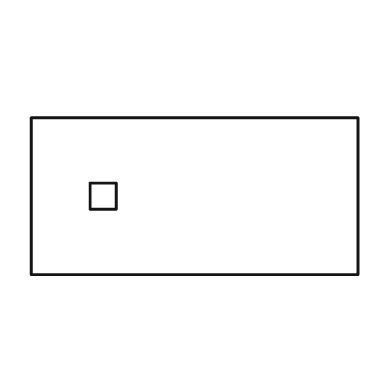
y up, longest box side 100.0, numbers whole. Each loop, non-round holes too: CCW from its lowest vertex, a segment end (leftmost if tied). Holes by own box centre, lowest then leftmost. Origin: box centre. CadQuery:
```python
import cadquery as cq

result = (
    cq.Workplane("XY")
    .moveTo(-50.0, -24.0)
    .lineTo(50.0, -24.0)
    .lineTo(50.0, 24.0)
    .lineTo(-50.0, 24.0)
    .close()
    .moveTo(-32.0, -4.0)
    .lineTo(-24.0, -4.0)
    .lineTo(-24.0, 4.0)
    .lineTo(-32.0, 4.0)
    .close()
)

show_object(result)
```